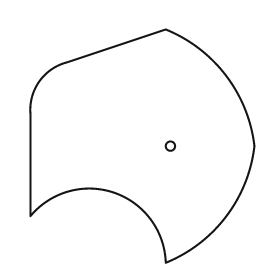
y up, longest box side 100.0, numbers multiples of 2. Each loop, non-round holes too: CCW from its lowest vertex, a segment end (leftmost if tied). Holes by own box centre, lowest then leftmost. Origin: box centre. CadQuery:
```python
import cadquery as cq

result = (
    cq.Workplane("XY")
    .moveTo(10.0, -50.0)
    .threePointArc((36.0, -30.0), (48.0, 0.0))
    .threePointArc((36.0, 30.0), (10.0, 50.0))
    .lineTo(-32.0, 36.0)
    .threePointArc((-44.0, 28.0), (-48.0, 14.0))
    .lineTo(-48.0, -30.0)
    .threePointArc((-12.0, -20.0), (10.0, -50.0))
    .close()
    .moveTo(12.0, 0.0)
    .circle(2.0)
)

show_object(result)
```